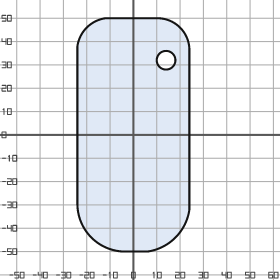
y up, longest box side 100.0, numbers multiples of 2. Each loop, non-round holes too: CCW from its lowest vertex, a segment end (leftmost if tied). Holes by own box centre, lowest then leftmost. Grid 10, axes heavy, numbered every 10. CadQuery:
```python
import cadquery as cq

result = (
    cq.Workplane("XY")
    .moveTo(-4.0, -50.0)
    .lineTo(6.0, -50.0)
    .threePointArc((18.0, -44.0), (24.0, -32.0))
    .lineTo(24.0, 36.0)
    .threePointArc((20.0, 46.0), (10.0, 50.0))
    .lineTo(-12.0, 50.0)
    .threePointArc((-20.0, 46.0), (-24.0, 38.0))
    .lineTo(-24.0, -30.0)
    .threePointArc((-18.0, -44.0), (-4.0, -50.0))
    .close()
    .moveTo(14.0, 32.0)
    .circle(4.0)
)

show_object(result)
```